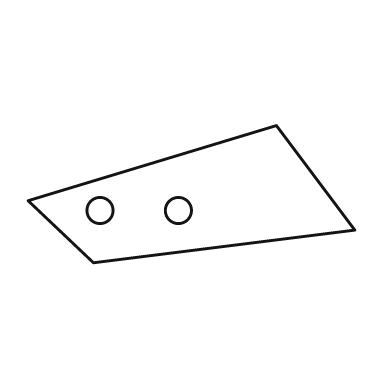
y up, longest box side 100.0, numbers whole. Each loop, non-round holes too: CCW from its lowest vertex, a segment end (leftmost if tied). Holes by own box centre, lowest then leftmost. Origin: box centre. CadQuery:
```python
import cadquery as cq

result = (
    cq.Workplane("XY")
    .moveTo(-30.0, -21.0)
    .lineTo(50.0, -11.0)
    .lineTo(26.0, 21.0)
    .lineTo(-50.0, -2.0)
    .close()
    .moveTo(-28.0, -5.0)
    .circle(4.0)
    .moveTo(-4.0, -5.0)
    .circle(4.0)
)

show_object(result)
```